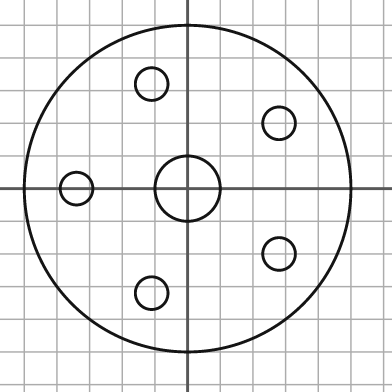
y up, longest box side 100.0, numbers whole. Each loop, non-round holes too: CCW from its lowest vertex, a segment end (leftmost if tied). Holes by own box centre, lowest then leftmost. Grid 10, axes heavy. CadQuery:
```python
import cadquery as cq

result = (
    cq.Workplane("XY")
    .moveTo(0.0, 0.0)
    .circle(50.0)
    .moveTo(-11.0, -32.0)
    .circle(5.0)
    .moveTo(28.0, -20.0)
    .circle(5.0)
    .moveTo(-34.0, 0.0)
    .circle(5.0)
    .moveTo(0.0, 0.0)
    .circle(10.0)
    .moveTo(28.0, 20.0)
    .circle(5.0)
    .moveTo(-11.0, 32.0)
    .circle(5.0)
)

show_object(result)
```